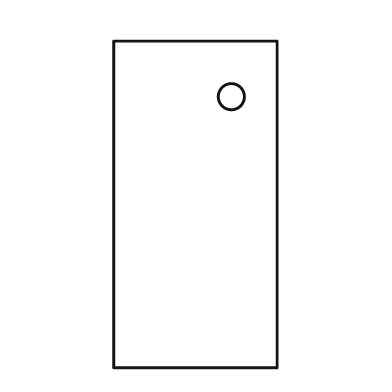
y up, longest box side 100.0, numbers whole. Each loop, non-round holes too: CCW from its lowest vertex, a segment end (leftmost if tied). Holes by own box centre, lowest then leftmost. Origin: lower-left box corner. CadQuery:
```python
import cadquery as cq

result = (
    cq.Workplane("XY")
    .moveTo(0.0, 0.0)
    .lineTo(50.0, 0.0)
    .lineTo(50.0, 100.0)
    .lineTo(0.0, 100.0)
    .close()
    .moveTo(36.0, 83.0)
    .circle(4.0)
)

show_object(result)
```